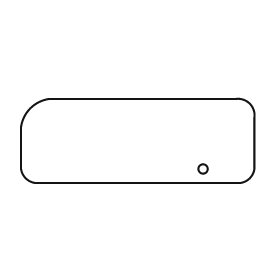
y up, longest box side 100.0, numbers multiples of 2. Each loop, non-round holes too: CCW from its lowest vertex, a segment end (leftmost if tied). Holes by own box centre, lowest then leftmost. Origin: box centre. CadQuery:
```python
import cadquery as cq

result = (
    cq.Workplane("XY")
    .moveTo(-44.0, -18.0)
    .lineTo(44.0, -18.0)
    .threePointArc((48.0, -16.0), (50.0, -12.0))
    .lineTo(50.0, 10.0)
    .threePointArc((48.0, 16.0), (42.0, 18.0))
    .lineTo(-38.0, 18.0)
    .threePointArc((-46.0, 14.0), (-50.0, 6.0))
    .lineTo(-50.0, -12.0)
    .threePointArc((-48.0, -16.0), (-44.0, -18.0))
    .close()
    .moveTo(28.0, -12.0)
    .circle(2.0)
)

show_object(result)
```